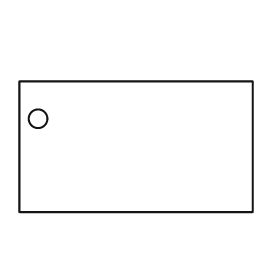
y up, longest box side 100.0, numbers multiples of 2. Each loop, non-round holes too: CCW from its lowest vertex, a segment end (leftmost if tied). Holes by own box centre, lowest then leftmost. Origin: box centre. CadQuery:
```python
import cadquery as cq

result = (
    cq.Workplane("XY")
    .moveTo(-50.0, -28.0)
    .lineTo(50.0, -28.0)
    .lineTo(50.0, 28.0)
    .lineTo(-50.0, 28.0)
    .close()
    .moveTo(-42.0, 12.0)
    .circle(4.0)
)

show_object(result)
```